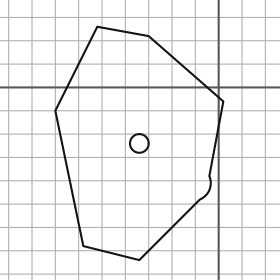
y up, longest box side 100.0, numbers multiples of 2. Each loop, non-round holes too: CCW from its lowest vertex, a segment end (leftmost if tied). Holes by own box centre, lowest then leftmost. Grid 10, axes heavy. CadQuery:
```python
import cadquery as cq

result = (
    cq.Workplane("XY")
    .moveTo(-34.0, -74.0)
    .lineTo(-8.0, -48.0)
    .threePointArc((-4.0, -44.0), (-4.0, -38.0))
    .lineTo(2.0, -6.0)
    .lineTo(-30.0, 22.0)
    .lineTo(-52.0, 26.0)
    .lineTo(-70.0, -10.0)
    .lineTo(-58.0, -68.0)
    .close()
    .moveTo(-34.0, -24.0)
    .circle(4.0)
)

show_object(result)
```